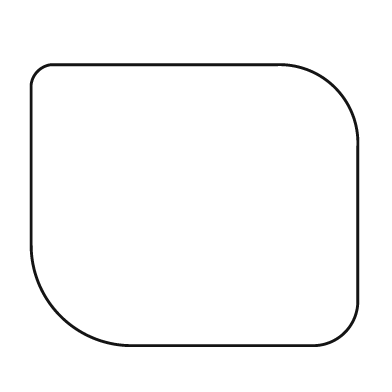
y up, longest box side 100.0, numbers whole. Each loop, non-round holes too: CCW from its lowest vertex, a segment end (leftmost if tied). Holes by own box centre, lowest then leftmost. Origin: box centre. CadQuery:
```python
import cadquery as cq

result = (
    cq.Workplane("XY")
    .moveTo(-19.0, -43.0)
    .lineTo(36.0, -43.0)
    .threePointArc((46.0, -39.0), (50.0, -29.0))
    .lineTo(50.0, 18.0)
    .threePointArc((43.0, 36.0), (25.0, 43.0))
    .lineTo(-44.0, 43.0)
    .threePointArc((-48.0, 41.0), (-50.0, 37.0))
    .lineTo(-50.0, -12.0)
    .threePointArc((-41.0, -34.0), (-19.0, -43.0))
    .close()
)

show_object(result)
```